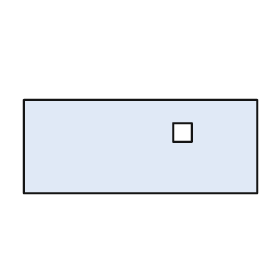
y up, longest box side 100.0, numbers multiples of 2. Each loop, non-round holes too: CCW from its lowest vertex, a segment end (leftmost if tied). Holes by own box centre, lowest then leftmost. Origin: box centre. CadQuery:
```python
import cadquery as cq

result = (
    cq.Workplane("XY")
    .moveTo(-50.0, -20.0)
    .lineTo(50.0, -20.0)
    .lineTo(50.0, 20.0)
    .lineTo(-50.0, 20.0)
    .close()
    .moveTo(14.0, 2.0)
    .lineTo(22.0, 2.0)
    .lineTo(22.0, 10.0)
    .lineTo(14.0, 10.0)
    .close()
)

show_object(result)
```